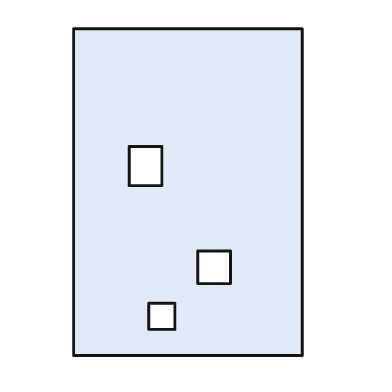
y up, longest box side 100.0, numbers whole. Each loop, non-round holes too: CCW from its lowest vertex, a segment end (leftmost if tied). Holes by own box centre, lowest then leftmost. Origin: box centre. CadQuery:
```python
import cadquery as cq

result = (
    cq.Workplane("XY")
    .moveTo(-35.0, -50.0)
    .lineTo(35.0, -50.0)
    .lineTo(35.0, 50.0)
    .lineTo(-35.0, 50.0)
    .close()
    .moveTo(-12.0, -42.0)
    .lineTo(-4.0, -42.0)
    .lineTo(-4.0, -34.0)
    .lineTo(-12.0, -34.0)
    .close()
    .moveTo(3.0, -28.0)
    .lineTo(13.0, -28.0)
    .lineTo(13.0, -18.0)
    .lineTo(3.0, -18.0)
    .close()
    .moveTo(-18.0, 2.0)
    .lineTo(-8.0, 2.0)
    .lineTo(-8.0, 14.0)
    .lineTo(-18.0, 14.0)
    .close()
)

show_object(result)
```